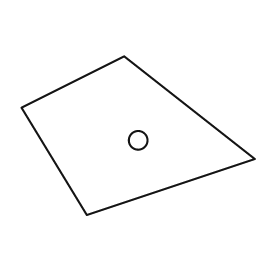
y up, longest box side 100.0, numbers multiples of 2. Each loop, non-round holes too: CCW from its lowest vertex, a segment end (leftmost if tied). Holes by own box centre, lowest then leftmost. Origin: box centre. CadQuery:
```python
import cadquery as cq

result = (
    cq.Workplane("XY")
    .moveTo(-22.0, -34.0)
    .lineTo(50.0, -10.0)
    .lineTo(-6.0, 34.0)
    .lineTo(-50.0, 12.0)
    .close()
    .moveTo(0.0, -2.0)
    .circle(4.0)
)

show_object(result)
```